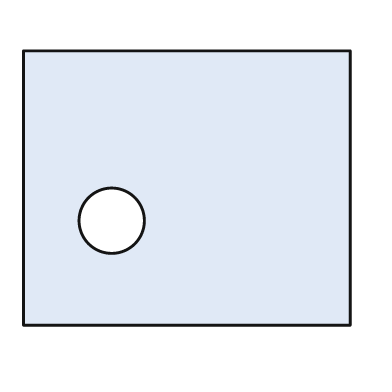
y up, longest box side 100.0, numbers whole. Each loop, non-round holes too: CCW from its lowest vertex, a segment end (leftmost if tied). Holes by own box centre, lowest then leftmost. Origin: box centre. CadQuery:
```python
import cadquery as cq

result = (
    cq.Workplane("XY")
    .moveTo(-50.0, -42.0)
    .lineTo(50.0, -42.0)
    .lineTo(50.0, 42.0)
    .lineTo(-50.0, 42.0)
    .close()
    .moveTo(-23.0, -10.0)
    .circle(10.0)
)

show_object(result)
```